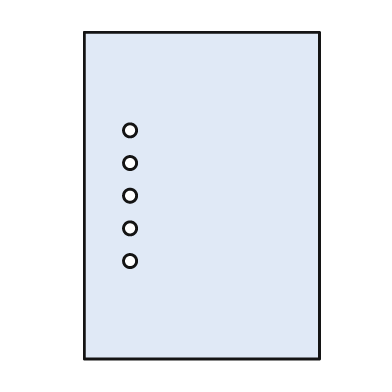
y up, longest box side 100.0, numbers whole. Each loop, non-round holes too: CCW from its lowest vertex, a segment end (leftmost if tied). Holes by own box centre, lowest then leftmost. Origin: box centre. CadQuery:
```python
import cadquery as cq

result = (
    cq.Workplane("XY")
    .moveTo(-36.0, -50.0)
    .lineTo(36.0, -50.0)
    .lineTo(36.0, 50.0)
    .lineTo(-36.0, 50.0)
    .close()
    .moveTo(-22.0, -20.0)
    .circle(2.0)
    .moveTo(-22.0, -10.0)
    .circle(2.0)
    .moveTo(-22.0, 0.0)
    .circle(2.0)
    .moveTo(-22.0, 10.0)
    .circle(2.0)
    .moveTo(-22.0, 20.0)
    .circle(2.0)
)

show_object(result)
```